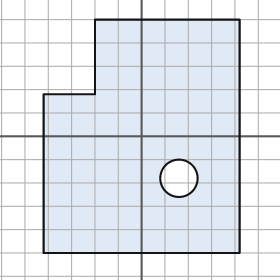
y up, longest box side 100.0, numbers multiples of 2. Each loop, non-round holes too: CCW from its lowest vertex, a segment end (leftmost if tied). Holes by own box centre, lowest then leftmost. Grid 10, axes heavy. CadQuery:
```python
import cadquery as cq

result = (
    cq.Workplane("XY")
    .moveTo(-42.0, -50.0)
    .lineTo(42.0, -50.0)
    .lineTo(42.0, 50.0)
    .lineTo(-20.0, 50.0)
    .lineTo(-20.0, 18.0)
    .lineTo(-42.0, 18.0)
    .close()
    .moveTo(16.0, -18.0)
    .circle(8.0)
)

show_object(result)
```